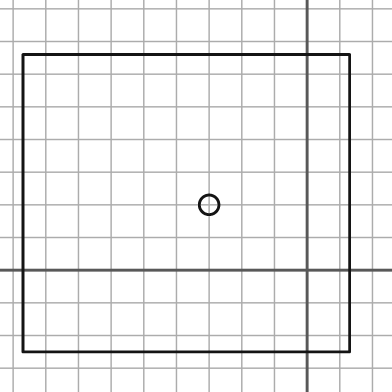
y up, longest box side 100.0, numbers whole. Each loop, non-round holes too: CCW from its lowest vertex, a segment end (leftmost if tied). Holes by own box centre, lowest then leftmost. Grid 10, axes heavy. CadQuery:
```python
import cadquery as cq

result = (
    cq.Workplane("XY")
    .moveTo(-87.0, -25.0)
    .lineTo(13.0, -25.0)
    .lineTo(13.0, 66.0)
    .lineTo(-87.0, 66.0)
    .close()
    .moveTo(-30.0, 20.0)
    .circle(3.0)
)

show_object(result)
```